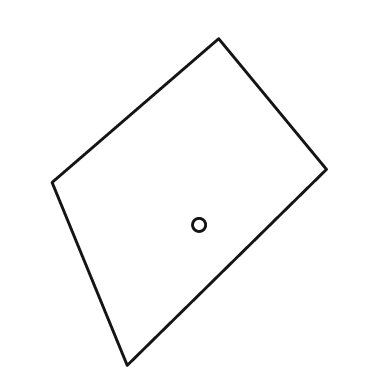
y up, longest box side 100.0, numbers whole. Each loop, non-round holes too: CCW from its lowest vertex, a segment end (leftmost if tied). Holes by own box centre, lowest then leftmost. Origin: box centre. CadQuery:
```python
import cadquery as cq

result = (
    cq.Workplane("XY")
    .moveTo(-19.0, -50.0)
    .lineTo(42.0, 10.0)
    .lineTo(9.0, 50.0)
    .lineTo(-42.0, 6.0)
    .close()
    .moveTo(3.0, -7.0)
    .circle(2.0)
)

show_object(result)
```